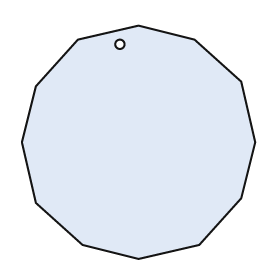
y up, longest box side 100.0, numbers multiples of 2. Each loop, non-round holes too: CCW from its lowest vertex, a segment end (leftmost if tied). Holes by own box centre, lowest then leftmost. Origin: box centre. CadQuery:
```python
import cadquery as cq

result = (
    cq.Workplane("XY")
    .moveTo(0.0, -50.0)
    .lineTo(26.0, -44.0)
    .lineTo(44.0, -24.0)
    .lineTo(50.0, 0.0)
    .lineTo(44.0, 26.0)
    .lineTo(24.0, 44.0)
    .lineTo(0.0, 50.0)
    .lineTo(-26.0, 44.0)
    .lineTo(-44.0, 24.0)
    .lineTo(-50.0, 0.0)
    .lineTo(-44.0, -26.0)
    .lineTo(-24.0, -44.0)
    .close()
    .moveTo(-8.0, 42.0)
    .circle(2.0)
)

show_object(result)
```